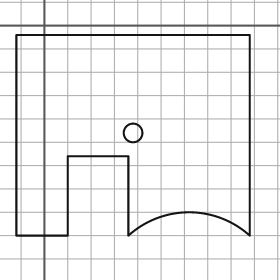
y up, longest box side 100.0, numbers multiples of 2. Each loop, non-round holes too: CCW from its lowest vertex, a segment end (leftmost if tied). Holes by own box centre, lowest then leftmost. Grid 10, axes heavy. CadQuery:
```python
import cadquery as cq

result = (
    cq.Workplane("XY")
    .moveTo(-12.0, -90.0)
    .lineTo(10.0, -90.0)
    .lineTo(10.0, -56.0)
    .lineTo(36.0, -56.0)
    .lineTo(36.0, -90.0)
    .threePointArc((62.0, -80.0), (88.0, -90.0))
    .lineTo(88.0, -4.0)
    .lineTo(-12.0, -4.0)
    .close()
    .moveTo(38.0, -46.0)
    .circle(4.0)
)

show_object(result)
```